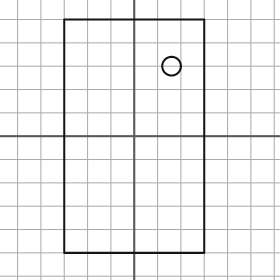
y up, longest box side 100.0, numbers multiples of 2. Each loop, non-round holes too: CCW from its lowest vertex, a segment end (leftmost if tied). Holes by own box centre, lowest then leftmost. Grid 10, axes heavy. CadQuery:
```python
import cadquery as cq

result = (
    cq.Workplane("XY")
    .moveTo(-30.0, -50.0)
    .lineTo(30.0, -50.0)
    .lineTo(30.0, 50.0)
    .lineTo(-30.0, 50.0)
    .close()
    .moveTo(16.0, 30.0)
    .circle(4.0)
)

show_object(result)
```